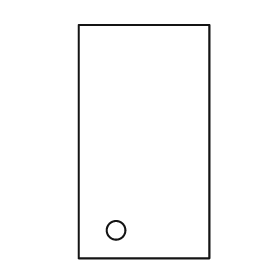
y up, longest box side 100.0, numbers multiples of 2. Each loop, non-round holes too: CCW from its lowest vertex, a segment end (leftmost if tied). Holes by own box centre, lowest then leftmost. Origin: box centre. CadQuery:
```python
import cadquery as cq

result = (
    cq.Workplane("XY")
    .moveTo(-28.0, -50.0)
    .lineTo(28.0, -50.0)
    .lineTo(28.0, 50.0)
    .lineTo(-28.0, 50.0)
    .close()
    .moveTo(-12.0, -38.0)
    .circle(4.0)
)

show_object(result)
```